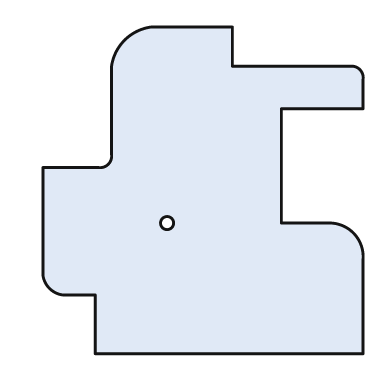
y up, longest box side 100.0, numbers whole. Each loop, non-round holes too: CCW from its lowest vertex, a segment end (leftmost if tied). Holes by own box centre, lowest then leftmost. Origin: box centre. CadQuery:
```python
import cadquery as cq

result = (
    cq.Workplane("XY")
    .moveTo(-33.0, -50.0)
    .lineTo(49.0, -50.0)
    .lineTo(49.0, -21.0)
    .threePointArc((46.0, -13.0), (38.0, -10.0))
    .lineTo(24.0, -10.0)
    .lineTo(24.0, 25.0)
    .lineTo(49.0, 25.0)
    .lineTo(49.0, 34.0)
    .threePointArc((48.0, 37.0), (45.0, 38.0))
    .lineTo(9.0, 38.0)
    .lineTo(9.0, 50.0)
    .lineTo(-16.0, 50.0)
    .threePointArc((-24.0, 46.0), (-28.0, 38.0))
    .lineTo(-28.0, 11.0)
    .threePointArc((-29.0, 8.0), (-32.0, 7.0))
    .lineTo(-49.0, 7.0)
    .lineTo(-49.0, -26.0)
    .threePointArc((-47.0, -30.0), (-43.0, -32.0))
    .lineTo(-33.0, -32.0)
    .close()
    .moveTo(-11.0, -10.0)
    .circle(2.0)
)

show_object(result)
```